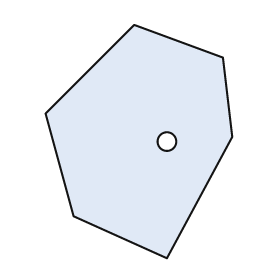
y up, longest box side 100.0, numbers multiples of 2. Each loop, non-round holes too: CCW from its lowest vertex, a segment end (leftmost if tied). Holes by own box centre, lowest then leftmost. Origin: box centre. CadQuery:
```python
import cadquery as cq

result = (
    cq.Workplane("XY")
    .moveTo(12.0, -50.0)
    .lineTo(40.0, 2.0)
    .lineTo(36.0, 36.0)
    .lineTo(-2.0, 50.0)
    .lineTo(-40.0, 12.0)
    .lineTo(-28.0, -32.0)
    .close()
    .moveTo(12.0, 0.0)
    .circle(4.0)
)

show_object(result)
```